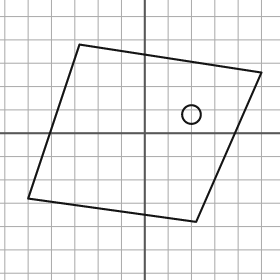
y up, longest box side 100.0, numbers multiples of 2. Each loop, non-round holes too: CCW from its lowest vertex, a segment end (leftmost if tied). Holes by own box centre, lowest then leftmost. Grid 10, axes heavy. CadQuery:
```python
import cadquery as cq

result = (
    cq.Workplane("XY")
    .moveTo(22.0, -38.0)
    .lineTo(50.0, 26.0)
    .lineTo(-28.0, 38.0)
    .lineTo(-50.0, -28.0)
    .close()
    .moveTo(20.0, 8.0)
    .circle(4.0)
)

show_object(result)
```